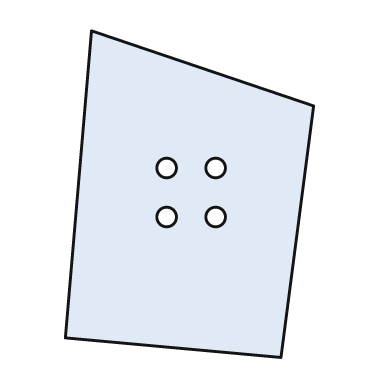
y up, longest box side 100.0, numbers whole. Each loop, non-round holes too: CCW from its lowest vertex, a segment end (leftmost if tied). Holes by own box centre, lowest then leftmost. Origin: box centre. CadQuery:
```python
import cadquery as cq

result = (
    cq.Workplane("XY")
    .moveTo(28.0, -50.0)
    .lineTo(38.0, 27.0)
    .lineTo(-30.0, 50.0)
    .lineTo(-38.0, -44.0)
    .close()
    .moveTo(-7.0, -7.0)
    .circle(3.0)
    .moveTo(8.0, -7.0)
    .circle(3.0)
    .moveTo(-7.0, 8.0)
    .circle(3.0)
    .moveTo(8.0, 8.0)
    .circle(3.0)
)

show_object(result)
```